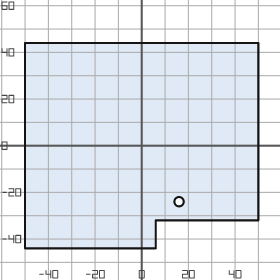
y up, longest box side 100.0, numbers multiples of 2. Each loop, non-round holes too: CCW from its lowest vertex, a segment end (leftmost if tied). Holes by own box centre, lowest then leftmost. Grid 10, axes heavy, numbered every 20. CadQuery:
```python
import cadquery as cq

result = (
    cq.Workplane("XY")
    .moveTo(-50.0, -44.0)
    .lineTo(6.0, -44.0)
    .lineTo(6.0, -32.0)
    .lineTo(50.0, -32.0)
    .lineTo(50.0, 44.0)
    .lineTo(-50.0, 44.0)
    .close()
    .moveTo(16.0, -24.0)
    .circle(2.0)
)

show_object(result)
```